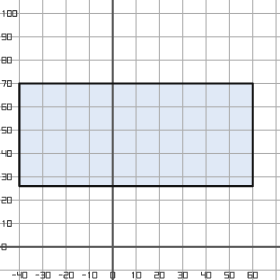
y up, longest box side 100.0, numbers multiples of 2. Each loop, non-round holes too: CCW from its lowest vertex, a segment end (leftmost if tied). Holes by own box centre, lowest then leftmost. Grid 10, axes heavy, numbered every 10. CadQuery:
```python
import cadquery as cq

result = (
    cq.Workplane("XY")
    .moveTo(-40.0, 26.0)
    .lineTo(60.0, 26.0)
    .lineTo(60.0, 70.0)
    .lineTo(-40.0, 70.0)
    .close()
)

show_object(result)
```